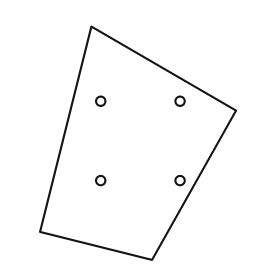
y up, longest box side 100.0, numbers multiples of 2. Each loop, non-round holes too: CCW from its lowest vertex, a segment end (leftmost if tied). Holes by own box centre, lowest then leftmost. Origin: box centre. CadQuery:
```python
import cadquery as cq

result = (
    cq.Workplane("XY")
    .moveTo(6.0, -50.0)
    .lineTo(42.0, 14.0)
    .lineTo(-20.0, 50.0)
    .lineTo(-42.0, -38.0)
    .close()
    .moveTo(-16.0, -16.0)
    .circle(2.0)
    .moveTo(18.0, -16.0)
    .circle(2.0)
    .moveTo(-16.0, 18.0)
    .circle(2.0)
    .moveTo(18.0, 18.0)
    .circle(2.0)
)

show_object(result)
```